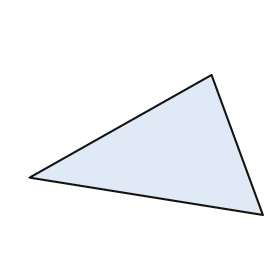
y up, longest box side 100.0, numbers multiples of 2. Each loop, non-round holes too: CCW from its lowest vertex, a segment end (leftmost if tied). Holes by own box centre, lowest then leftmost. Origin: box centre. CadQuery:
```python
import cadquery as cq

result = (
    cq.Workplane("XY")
    .moveTo(50.0, -30.0)
    .lineTo(28.0, 30.0)
    .lineTo(-50.0, -14.0)
    .close()
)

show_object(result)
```